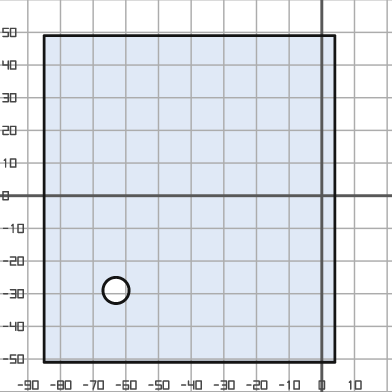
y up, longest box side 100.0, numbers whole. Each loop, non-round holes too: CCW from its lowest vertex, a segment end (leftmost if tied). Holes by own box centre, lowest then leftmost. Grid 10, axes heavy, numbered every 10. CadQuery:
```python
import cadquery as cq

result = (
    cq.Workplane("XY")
    .moveTo(-85.0, -51.0)
    .lineTo(4.0, -51.0)
    .lineTo(4.0, 49.0)
    .lineTo(-85.0, 49.0)
    .close()
    .moveTo(-63.0, -29.0)
    .circle(4.0)
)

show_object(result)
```